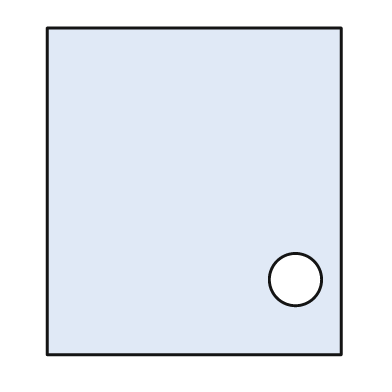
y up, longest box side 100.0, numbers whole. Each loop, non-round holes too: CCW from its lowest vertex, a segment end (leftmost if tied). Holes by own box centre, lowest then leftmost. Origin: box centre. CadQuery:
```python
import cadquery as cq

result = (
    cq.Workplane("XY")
    .moveTo(-45.0, -50.0)
    .lineTo(45.0, -50.0)
    .lineTo(45.0, 50.0)
    .lineTo(-45.0, 50.0)
    .close()
    .moveTo(31.0, -27.0)
    .circle(8.0)
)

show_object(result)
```